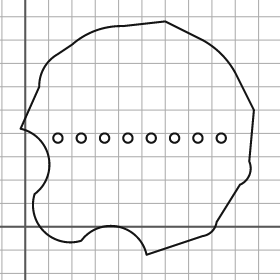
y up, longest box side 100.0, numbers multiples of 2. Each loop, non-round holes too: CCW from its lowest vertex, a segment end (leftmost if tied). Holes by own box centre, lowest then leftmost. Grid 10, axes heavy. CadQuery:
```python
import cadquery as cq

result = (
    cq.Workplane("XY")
    .moveTo(52.0, -12.0)
    .lineTo(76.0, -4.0)
    .threePointArc((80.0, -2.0), (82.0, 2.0))
    .lineTo(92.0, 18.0)
    .threePointArc((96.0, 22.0), (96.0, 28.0))
    .lineTo(98.0, 50.0)
    .lineTo(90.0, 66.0)
    .threePointArc((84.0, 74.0), (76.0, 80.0))
    .lineTo(60.0, 88.0)
    .lineTo(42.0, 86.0)
    .threePointArc((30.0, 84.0), (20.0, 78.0))
    .lineTo(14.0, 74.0)
    .threePointArc((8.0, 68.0), (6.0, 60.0))
    .lineTo(-2.0, 42.0)
    .threePointArc((10.0, 30.0), (4.0, 14.0))
    .threePointArc((8.0, -2.0), (24.0, -6.0))
    .threePointArc((40.0, 0.0), (52.0, -12.0))
    .close()
    .moveTo(14.0, 38.0)
    .circle(2.0)
    .moveTo(24.0, 38.0)
    .circle(2.0)
    .moveTo(34.0, 38.0)
    .circle(2.0)
    .moveTo(44.0, 38.0)
    .circle(2.0)
    .moveTo(54.0, 38.0)
    .circle(2.0)
    .moveTo(64.0, 38.0)
    .circle(2.0)
    .moveTo(74.0, 38.0)
    .circle(2.0)
    .moveTo(84.0, 38.0)
    .circle(2.0)
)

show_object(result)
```